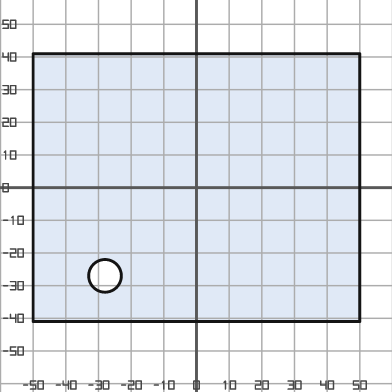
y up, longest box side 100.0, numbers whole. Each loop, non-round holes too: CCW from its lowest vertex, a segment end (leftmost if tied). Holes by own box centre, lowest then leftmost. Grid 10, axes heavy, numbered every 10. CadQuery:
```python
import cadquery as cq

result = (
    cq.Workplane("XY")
    .moveTo(-50.0, -41.0)
    .lineTo(50.0, -41.0)
    .lineTo(50.0, 41.0)
    .lineTo(-50.0, 41.0)
    .close()
    .moveTo(-28.0, -27.0)
    .circle(5.0)
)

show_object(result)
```